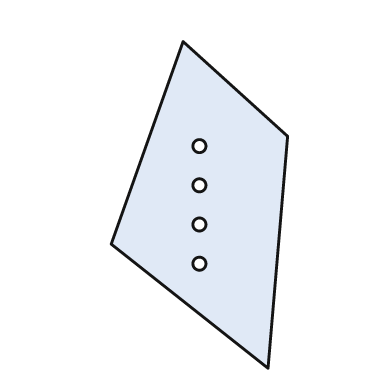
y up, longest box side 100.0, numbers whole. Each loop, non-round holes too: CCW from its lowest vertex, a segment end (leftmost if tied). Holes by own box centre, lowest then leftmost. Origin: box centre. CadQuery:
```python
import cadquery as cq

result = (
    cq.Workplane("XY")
    .moveTo(21.0, -50.0)
    .lineTo(27.0, 21.0)
    .lineTo(-5.0, 50.0)
    .lineTo(-27.0, -12.0)
    .close()
    .moveTo(0.0, -18.0)
    .circle(2.0)
    .moveTo(0.0, -6.0)
    .circle(2.0)
    .moveTo(0.0, 6.0)
    .circle(2.0)
    .moveTo(0.0, 18.0)
    .circle(2.0)
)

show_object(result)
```